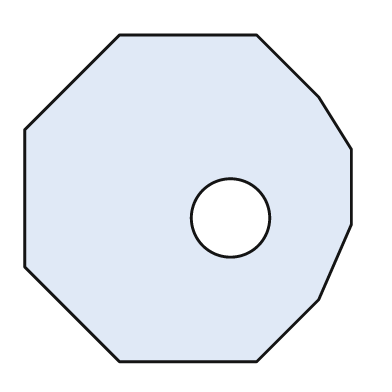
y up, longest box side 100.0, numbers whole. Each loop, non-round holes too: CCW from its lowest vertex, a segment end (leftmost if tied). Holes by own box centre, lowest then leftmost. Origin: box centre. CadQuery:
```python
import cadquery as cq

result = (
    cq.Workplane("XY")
    .moveTo(-21.0, -50.0)
    .lineTo(21.0, -50.0)
    .lineTo(40.0, -31.0)
    .lineTo(50.0, -8.0)
    .lineTo(50.0, 15.0)
    .lineTo(40.0, 31.0)
    .lineTo(21.0, 50.0)
    .lineTo(-21.0, 50.0)
    .lineTo(-50.0, 21.0)
    .lineTo(-50.0, -21.0)
    .close()
    .moveTo(13.0, -6.0)
    .circle(12.0)
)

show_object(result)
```